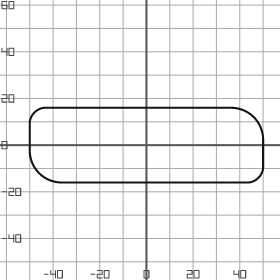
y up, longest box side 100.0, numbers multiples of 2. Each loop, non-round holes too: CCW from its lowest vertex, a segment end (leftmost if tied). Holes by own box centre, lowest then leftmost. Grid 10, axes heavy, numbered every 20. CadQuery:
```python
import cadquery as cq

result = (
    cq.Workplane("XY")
    .moveTo(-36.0, -16.0)
    .lineTo(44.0, -16.0)
    .threePointArc((48.0, -14.0), (50.0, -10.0))
    .lineTo(50.0, 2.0)
    .threePointArc((46.0, 12.0), (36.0, 16.0))
    .lineTo(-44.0, 16.0)
    .threePointArc((-48.0, 14.0), (-50.0, 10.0))
    .lineTo(-50.0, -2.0)
    .threePointArc((-46.0, -12.0), (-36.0, -16.0))
    .close()
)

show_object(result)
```